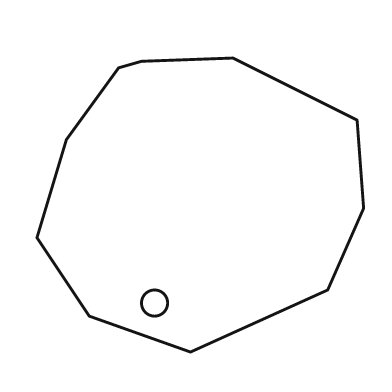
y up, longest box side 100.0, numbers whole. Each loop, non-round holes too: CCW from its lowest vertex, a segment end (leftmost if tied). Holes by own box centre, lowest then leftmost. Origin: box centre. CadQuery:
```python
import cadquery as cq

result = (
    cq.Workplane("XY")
    .moveTo(-3.0, -45.0)
    .lineTo(39.0, -26.0)
    .lineTo(50.0, -1.0)
    .lineTo(48.0, 26.0)
    .lineTo(10.0, 45.0)
    .lineTo(-18.0, 44.0)
    .lineTo(-25.0, 42.0)
    .lineTo(-41.0, 20.0)
    .lineTo(-50.0, -10.0)
    .lineTo(-34.0, -34.0)
    .close()
    .moveTo(-14.0, -30.0)
    .circle(4.0)
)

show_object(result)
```